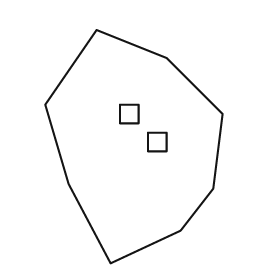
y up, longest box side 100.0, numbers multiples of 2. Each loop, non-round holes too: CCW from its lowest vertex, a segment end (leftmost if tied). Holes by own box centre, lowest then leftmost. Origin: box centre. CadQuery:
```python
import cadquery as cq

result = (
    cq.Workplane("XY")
    .moveTo(-10.0, -50.0)
    .lineTo(20.0, -36.0)
    .lineTo(34.0, -18.0)
    .lineTo(38.0, 14.0)
    .lineTo(14.0, 38.0)
    .lineTo(-16.0, 50.0)
    .lineTo(-38.0, 18.0)
    .lineTo(-28.0, -16.0)
    .close()
    .moveTo(6.0, -2.0)
    .lineTo(14.0, -2.0)
    .lineTo(14.0, 6.0)
    .lineTo(6.0, 6.0)
    .close()
    .moveTo(-6.0, 10.0)
    .lineTo(2.0, 10.0)
    .lineTo(2.0, 18.0)
    .lineTo(-6.0, 18.0)
    .close()
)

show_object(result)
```